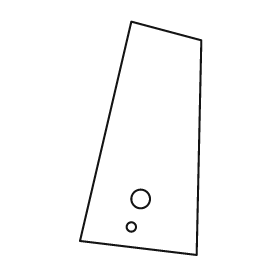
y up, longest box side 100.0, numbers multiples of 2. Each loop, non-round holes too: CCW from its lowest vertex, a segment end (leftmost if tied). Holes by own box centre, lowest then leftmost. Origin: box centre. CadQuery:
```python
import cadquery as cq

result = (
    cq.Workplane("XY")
    .moveTo(24.0, -50.0)
    .lineTo(26.0, 42.0)
    .lineTo(-4.0, 50.0)
    .lineTo(-26.0, -44.0)
    .close()
    .moveTo(-4.0, -38.0)
    .circle(2.0)
    .moveTo(0.0, -26.0)
    .circle(4.0)
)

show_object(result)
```